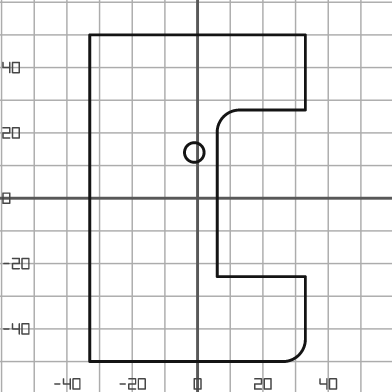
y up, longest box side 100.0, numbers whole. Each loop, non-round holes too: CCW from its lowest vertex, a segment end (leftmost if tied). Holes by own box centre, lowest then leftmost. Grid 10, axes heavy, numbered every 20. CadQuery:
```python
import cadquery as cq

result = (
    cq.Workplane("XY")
    .moveTo(-33.0, -50.0)
    .lineTo(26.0, -50.0)
    .threePointArc((31.0, -48.0), (33.0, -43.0))
    .lineTo(33.0, -24.0)
    .lineTo(6.0, -24.0)
    .lineTo(6.0, 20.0)
    .threePointArc((8.0, 25.0), (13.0, 27.0))
    .lineTo(33.0, 27.0)
    .lineTo(33.0, 50.0)
    .lineTo(-33.0, 50.0)
    .close()
    .moveTo(-1.0, 14.0)
    .circle(3.0)
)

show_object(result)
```